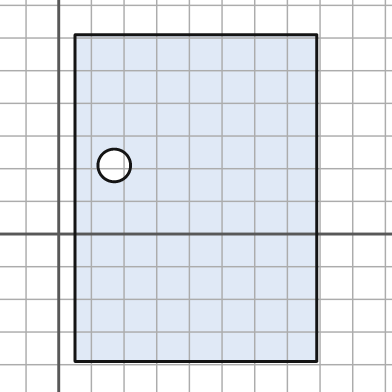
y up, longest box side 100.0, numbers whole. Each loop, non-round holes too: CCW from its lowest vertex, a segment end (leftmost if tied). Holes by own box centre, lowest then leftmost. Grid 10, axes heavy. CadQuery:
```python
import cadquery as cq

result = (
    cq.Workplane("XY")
    .moveTo(5.0, -39.0)
    .lineTo(79.0, -39.0)
    .lineTo(79.0, 61.0)
    .lineTo(5.0, 61.0)
    .close()
    .moveTo(17.0, 21.0)
    .circle(5.0)
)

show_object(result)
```